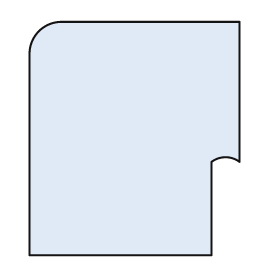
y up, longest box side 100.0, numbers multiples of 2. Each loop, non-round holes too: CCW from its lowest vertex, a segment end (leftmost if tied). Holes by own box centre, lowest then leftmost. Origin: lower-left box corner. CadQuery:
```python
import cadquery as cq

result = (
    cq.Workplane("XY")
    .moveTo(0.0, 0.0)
    .lineTo(78.0, 0.0)
    .lineTo(78.0, 40.0)
    .threePointArc((84.0, 42.0), (90.0, 40.0))
    .lineTo(90.0, 100.0)
    .lineTo(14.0, 100.0)
    .threePointArc((4.0, 96.0), (0.0, 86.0))
    .close()
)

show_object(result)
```